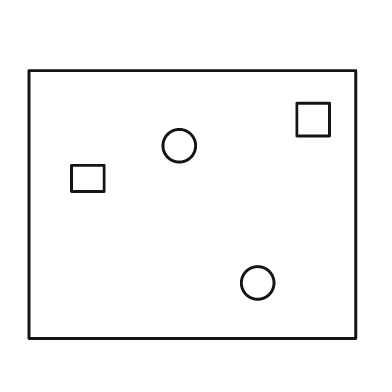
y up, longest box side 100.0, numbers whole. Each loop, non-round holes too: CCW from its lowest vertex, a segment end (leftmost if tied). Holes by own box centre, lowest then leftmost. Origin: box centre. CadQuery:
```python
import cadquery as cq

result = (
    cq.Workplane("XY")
    .moveTo(-50.0, -41.0)
    .lineTo(50.0, -41.0)
    .lineTo(50.0, 41.0)
    .lineTo(-50.0, 41.0)
    .close()
    .moveTo(20.0, -24.0)
    .circle(5.0)
    .moveTo(-37.0, 4.0)
    .lineTo(-27.0, 4.0)
    .lineTo(-27.0, 12.0)
    .lineTo(-37.0, 12.0)
    .close()
    .moveTo(-4.0, 18.0)
    .circle(5.0)
    .moveTo(32.0, 21.0)
    .lineTo(42.0, 21.0)
    .lineTo(42.0, 31.0)
    .lineTo(32.0, 31.0)
    .close()
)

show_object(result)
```